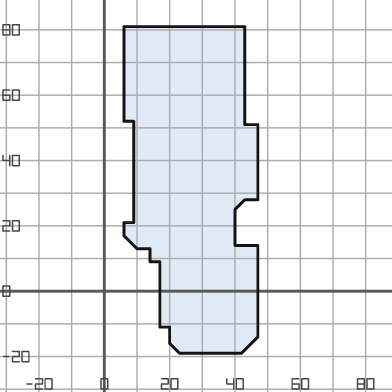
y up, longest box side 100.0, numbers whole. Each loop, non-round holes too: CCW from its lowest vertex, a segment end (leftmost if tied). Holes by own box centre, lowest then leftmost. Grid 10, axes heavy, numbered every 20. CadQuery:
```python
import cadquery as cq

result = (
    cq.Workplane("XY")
    .moveTo(23.0, -19.0)
    .lineTo(42.0, -19.0)
    .lineTo(47.0, -14.0)
    .lineTo(47.0, 14.0)
    .lineTo(40.0, 14.0)
    .lineTo(40.0, 25.0)
    .lineTo(43.0, 28.0)
    .lineTo(47.0, 28.0)
    .lineTo(47.0, 51.0)
    .lineTo(43.0, 51.0)
    .lineTo(43.0, 81.0)
    .lineTo(6.0, 81.0)
    .lineTo(6.0, 52.0)
    .lineTo(9.0, 52.0)
    .lineTo(9.0, 21.0)
    .lineTo(6.0, 21.0)
    .lineTo(6.0, 17.0)
    .lineTo(10.0, 13.0)
    .lineTo(14.0, 13.0)
    .lineTo(14.0, 9.0)
    .lineTo(17.0, 9.0)
    .lineTo(17.0, -11.0)
    .lineTo(20.0, -11.0)
    .lineTo(20.0, -16.0)
    .close()
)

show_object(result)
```